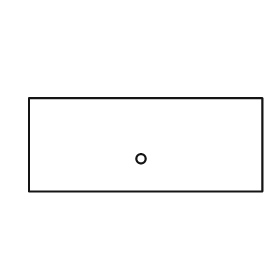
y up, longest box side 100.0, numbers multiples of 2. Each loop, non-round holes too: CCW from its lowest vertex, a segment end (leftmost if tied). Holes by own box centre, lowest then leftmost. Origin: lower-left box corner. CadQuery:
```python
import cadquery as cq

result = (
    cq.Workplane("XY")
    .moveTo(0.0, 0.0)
    .lineTo(100.0, 0.0)
    .lineTo(100.0, 40.0)
    .lineTo(0.0, 40.0)
    .close()
    .moveTo(48.0, 14.0)
    .circle(2.0)
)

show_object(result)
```